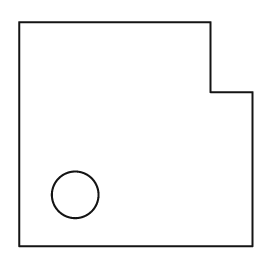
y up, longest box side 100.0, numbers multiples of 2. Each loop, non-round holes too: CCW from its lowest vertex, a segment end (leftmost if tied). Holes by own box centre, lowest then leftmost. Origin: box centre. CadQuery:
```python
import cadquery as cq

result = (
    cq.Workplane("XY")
    .moveTo(-50.0, -48.0)
    .lineTo(50.0, -48.0)
    .lineTo(50.0, 18.0)
    .lineTo(32.0, 18.0)
    .lineTo(32.0, 48.0)
    .lineTo(-50.0, 48.0)
    .close()
    .moveTo(-26.0, -26.0)
    .circle(10.0)
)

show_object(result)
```